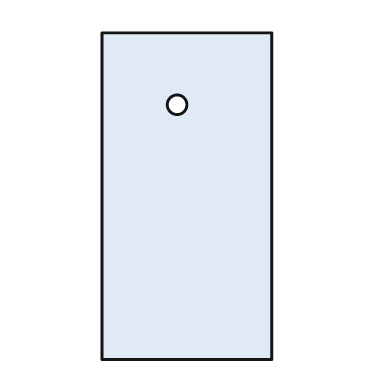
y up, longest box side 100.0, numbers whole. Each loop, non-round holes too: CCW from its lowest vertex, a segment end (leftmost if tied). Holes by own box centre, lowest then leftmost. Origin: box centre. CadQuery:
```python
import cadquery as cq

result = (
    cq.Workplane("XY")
    .moveTo(-26.0, -50.0)
    .lineTo(26.0, -50.0)
    .lineTo(26.0, 50.0)
    .lineTo(-26.0, 50.0)
    .close()
    .moveTo(-3.0, 28.0)
    .circle(3.0)
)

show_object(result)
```